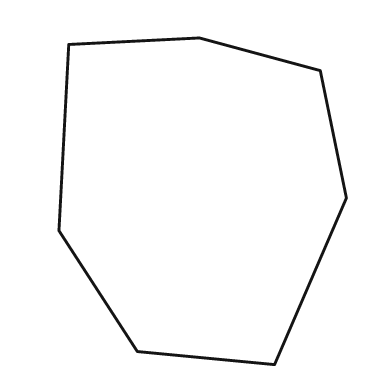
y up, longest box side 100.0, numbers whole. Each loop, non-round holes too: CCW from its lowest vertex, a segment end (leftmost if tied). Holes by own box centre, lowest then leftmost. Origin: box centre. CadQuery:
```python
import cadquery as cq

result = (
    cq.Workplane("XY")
    .moveTo(22.0, -50.0)
    .lineTo(44.0, 1.0)
    .lineTo(36.0, 40.0)
    .lineTo(-1.0, 50.0)
    .lineTo(-41.0, 48.0)
    .lineTo(-44.0, -9.0)
    .lineTo(-20.0, -46.0)
    .close()
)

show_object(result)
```